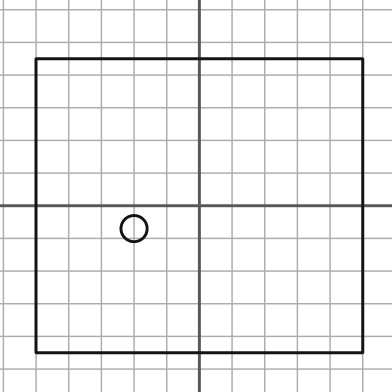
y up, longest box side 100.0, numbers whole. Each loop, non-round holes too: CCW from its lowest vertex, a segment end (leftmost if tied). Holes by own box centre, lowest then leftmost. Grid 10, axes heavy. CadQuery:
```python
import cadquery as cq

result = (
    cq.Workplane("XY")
    .moveTo(-50.0, -45.0)
    .lineTo(50.0, -45.0)
    .lineTo(50.0, 45.0)
    .lineTo(-50.0, 45.0)
    .close()
    .moveTo(-20.0, -7.0)
    .circle(4.0)
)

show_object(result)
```